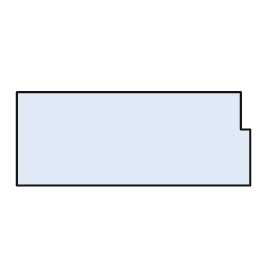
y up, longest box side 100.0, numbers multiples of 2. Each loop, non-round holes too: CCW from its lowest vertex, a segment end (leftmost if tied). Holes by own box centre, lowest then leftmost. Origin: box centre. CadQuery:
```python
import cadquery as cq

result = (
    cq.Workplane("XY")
    .moveTo(-50.0, -20.0)
    .lineTo(50.0, -20.0)
    .lineTo(50.0, 4.0)
    .lineTo(46.0, 4.0)
    .lineTo(46.0, 20.0)
    .lineTo(-50.0, 20.0)
    .close()
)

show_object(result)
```